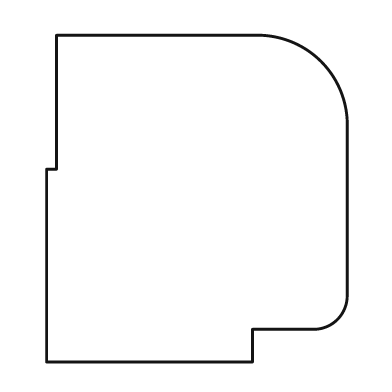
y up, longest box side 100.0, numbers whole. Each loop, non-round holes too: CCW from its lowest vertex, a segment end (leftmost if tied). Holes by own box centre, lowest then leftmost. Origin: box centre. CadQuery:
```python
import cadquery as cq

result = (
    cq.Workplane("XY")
    .moveTo(-46.0, -50.0)
    .lineTo(17.0, -50.0)
    .lineTo(17.0, -40.0)
    .lineTo(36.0, -40.0)
    .threePointArc((43.0, -37.0), (46.0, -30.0))
    .lineTo(46.0, 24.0)
    .threePointArc((38.0, 42.0), (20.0, 50.0))
    .lineTo(-43.0, 50.0)
    .lineTo(-43.0, 9.0)
    .lineTo(-46.0, 9.0)
    .close()
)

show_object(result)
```